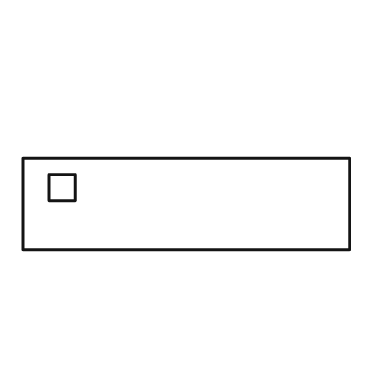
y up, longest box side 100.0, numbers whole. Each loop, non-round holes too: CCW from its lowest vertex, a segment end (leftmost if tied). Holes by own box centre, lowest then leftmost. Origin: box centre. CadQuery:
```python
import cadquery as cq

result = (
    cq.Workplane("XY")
    .moveTo(-50.0, -14.0)
    .lineTo(50.0, -14.0)
    .lineTo(50.0, 14.0)
    .lineTo(-50.0, 14.0)
    .close()
    .moveTo(-42.0, 1.0)
    .lineTo(-34.0, 1.0)
    .lineTo(-34.0, 9.0)
    .lineTo(-42.0, 9.0)
    .close()
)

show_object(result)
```